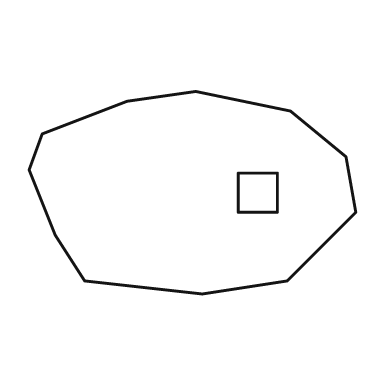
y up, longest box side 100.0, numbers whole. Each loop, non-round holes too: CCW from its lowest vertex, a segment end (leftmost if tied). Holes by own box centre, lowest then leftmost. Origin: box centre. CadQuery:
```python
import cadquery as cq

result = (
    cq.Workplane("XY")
    .moveTo(3.0, -31.0)
    .lineTo(29.0, -27.0)
    .lineTo(50.0, -6.0)
    .lineTo(47.0, 11.0)
    .lineTo(30.0, 25.0)
    .lineTo(1.0, 31.0)
    .lineTo(-20.0, 28.0)
    .lineTo(-46.0, 18.0)
    .lineTo(-50.0, 7.0)
    .lineTo(-42.0, -13.0)
    .lineTo(-33.0, -27.0)
    .close()
    .moveTo(14.0, -6.0)
    .lineTo(26.0, -6.0)
    .lineTo(26.0, 6.0)
    .lineTo(14.0, 6.0)
    .close()
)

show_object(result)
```